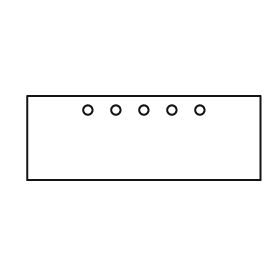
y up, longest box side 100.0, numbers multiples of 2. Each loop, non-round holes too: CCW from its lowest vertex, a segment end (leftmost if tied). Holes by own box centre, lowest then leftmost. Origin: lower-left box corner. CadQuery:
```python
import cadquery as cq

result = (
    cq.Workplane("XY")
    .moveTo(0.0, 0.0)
    .lineTo(100.0, 0.0)
    .lineTo(100.0, 36.0)
    .lineTo(0.0, 36.0)
    .close()
    .moveTo(26.0, 30.0)
    .circle(2.0)
    .moveTo(38.0, 30.0)
    .circle(2.0)
    .moveTo(50.0, 30.0)
    .circle(2.0)
    .moveTo(62.0, 30.0)
    .circle(2.0)
    .moveTo(74.0, 30.0)
    .circle(2.0)
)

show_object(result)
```